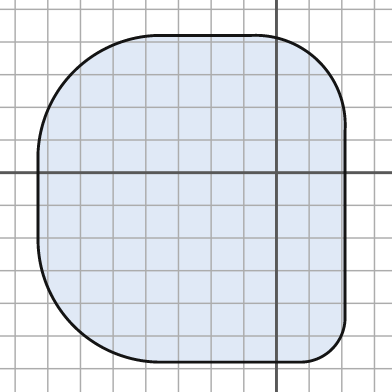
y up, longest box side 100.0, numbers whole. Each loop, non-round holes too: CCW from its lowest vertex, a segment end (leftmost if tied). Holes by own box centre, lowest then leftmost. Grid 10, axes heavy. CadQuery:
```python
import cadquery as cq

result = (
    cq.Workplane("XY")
    .moveTo(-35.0, -58.0)
    .lineTo(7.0, -58.0)
    .threePointArc((17.0, -54.0), (21.0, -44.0))
    .lineTo(21.0, 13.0)
    .threePointArc((13.0, 34.0), (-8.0, 42.0))
    .lineTo(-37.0, 42.0)
    .threePointArc((-62.0, 31.0), (-73.0, 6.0))
    .lineTo(-73.0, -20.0)
    .threePointArc((-62.0, -47.0), (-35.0, -58.0))
    .close()
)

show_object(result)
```